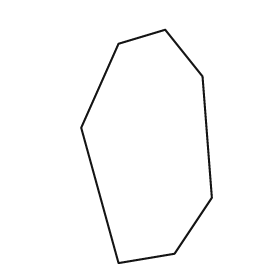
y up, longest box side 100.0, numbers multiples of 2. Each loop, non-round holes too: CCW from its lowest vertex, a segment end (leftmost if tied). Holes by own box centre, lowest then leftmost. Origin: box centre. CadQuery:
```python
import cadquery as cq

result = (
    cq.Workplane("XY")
    .moveTo(-12.0, -50.0)
    .lineTo(12.0, -46.0)
    .lineTo(28.0, -22.0)
    .lineTo(24.0, 30.0)
    .lineTo(8.0, 50.0)
    .lineTo(-12.0, 44.0)
    .lineTo(-28.0, 8.0)
    .close()
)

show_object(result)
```